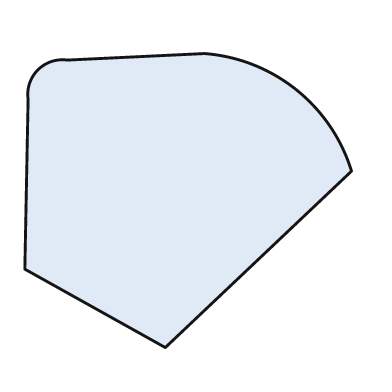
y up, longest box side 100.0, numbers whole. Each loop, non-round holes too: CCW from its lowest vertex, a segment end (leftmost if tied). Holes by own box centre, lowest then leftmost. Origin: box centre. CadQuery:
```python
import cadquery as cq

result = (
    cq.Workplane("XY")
    .moveTo(-7.0, -45.0)
    .lineTo(50.0, 9.0)
    .threePointArc((33.0, 34.0), (5.0, 45.0))
    .lineTo(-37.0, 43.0)
    .threePointArc((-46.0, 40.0), (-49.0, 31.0))
    .lineTo(-50.0, -21.0)
    .close()
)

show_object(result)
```